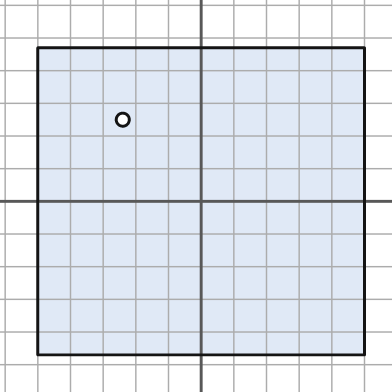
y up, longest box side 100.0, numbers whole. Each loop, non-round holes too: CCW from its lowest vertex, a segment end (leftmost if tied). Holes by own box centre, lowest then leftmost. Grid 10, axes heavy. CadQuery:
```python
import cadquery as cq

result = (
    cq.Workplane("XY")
    .moveTo(-50.0, -47.0)
    .lineTo(50.0, -47.0)
    .lineTo(50.0, 47.0)
    .lineTo(-50.0, 47.0)
    .close()
    .moveTo(-24.0, 25.0)
    .circle(2.0)
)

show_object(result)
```